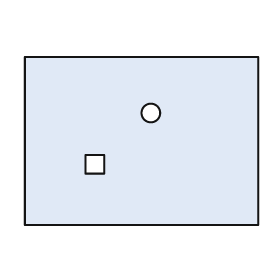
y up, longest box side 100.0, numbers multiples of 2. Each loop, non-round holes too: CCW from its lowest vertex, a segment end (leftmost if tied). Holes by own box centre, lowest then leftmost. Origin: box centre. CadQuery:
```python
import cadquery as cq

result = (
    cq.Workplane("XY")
    .moveTo(-50.0, -36.0)
    .lineTo(50.0, -36.0)
    .lineTo(50.0, 36.0)
    .lineTo(-50.0, 36.0)
    .close()
    .moveTo(-24.0, -14.0)
    .lineTo(-16.0, -14.0)
    .lineTo(-16.0, -6.0)
    .lineTo(-24.0, -6.0)
    .close()
    .moveTo(4.0, 12.0)
    .circle(4.0)
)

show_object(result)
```